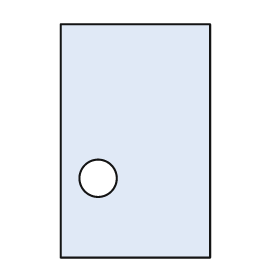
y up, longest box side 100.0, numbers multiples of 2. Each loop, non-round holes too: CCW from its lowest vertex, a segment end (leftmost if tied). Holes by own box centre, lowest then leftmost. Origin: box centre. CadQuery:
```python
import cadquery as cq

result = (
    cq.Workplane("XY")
    .moveTo(-32.0, -50.0)
    .lineTo(32.0, -50.0)
    .lineTo(32.0, 50.0)
    .lineTo(-32.0, 50.0)
    .close()
    .moveTo(-16.0, -16.0)
    .circle(8.0)
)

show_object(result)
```